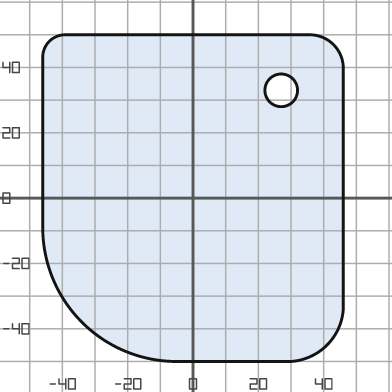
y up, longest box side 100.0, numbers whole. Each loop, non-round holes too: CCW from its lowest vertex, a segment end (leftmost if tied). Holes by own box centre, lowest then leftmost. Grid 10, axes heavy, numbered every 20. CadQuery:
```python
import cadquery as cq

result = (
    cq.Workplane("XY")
    .moveTo(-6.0, -50.0)
    .lineTo(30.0, -50.0)
    .threePointArc((41.0, -45.0), (46.0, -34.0))
    .lineTo(46.0, 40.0)
    .threePointArc((43.0, 47.0), (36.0, 50.0))
    .lineTo(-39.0, 50.0)
    .threePointArc((-44.0, 48.0), (-46.0, 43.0))
    .lineTo(-46.0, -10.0)
    .threePointArc((-34.0, -38.0), (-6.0, -50.0))
    .close()
    .moveTo(27.0, 33.0)
    .circle(5.0)
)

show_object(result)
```